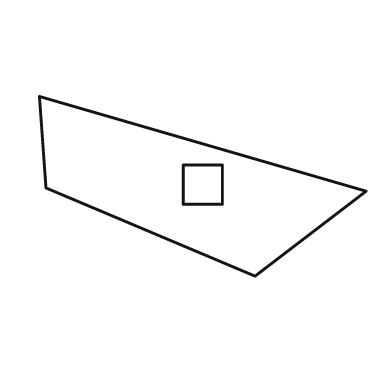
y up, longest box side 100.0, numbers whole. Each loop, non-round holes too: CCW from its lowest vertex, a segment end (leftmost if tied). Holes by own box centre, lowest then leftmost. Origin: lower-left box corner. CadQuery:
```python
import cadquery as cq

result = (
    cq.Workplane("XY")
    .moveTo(66.0, 0.0)
    .lineTo(100.0, 26.0)
    .lineTo(0.0, 55.0)
    .lineTo(2.0, 27.0)
    .close()
    .moveTo(44.0, 22.0)
    .lineTo(56.0, 22.0)
    .lineTo(56.0, 34.0)
    .lineTo(44.0, 34.0)
    .close()
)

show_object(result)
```